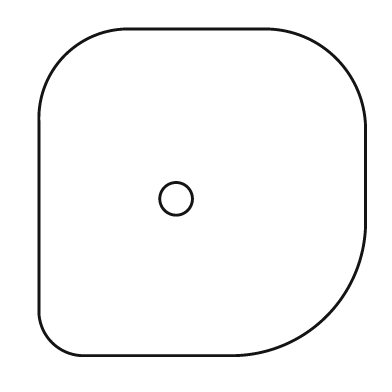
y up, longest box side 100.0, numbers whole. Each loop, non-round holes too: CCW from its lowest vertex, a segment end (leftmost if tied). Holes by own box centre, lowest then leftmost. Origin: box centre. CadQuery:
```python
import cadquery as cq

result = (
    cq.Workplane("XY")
    .moveTo(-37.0, -50.0)
    .lineTo(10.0, -50.0)
    .threePointArc((38.0, -38.0), (50.0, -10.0))
    .lineTo(50.0, 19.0)
    .threePointArc((41.0, 41.0), (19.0, 50.0))
    .lineTo(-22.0, 50.0)
    .threePointArc((-42.0, 42.0), (-50.0, 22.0))
    .lineTo(-50.0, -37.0)
    .threePointArc((-46.0, -46.0), (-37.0, -50.0))
    .close()
    .moveTo(-8.0, -2.0)
    .circle(5.0)
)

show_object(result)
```